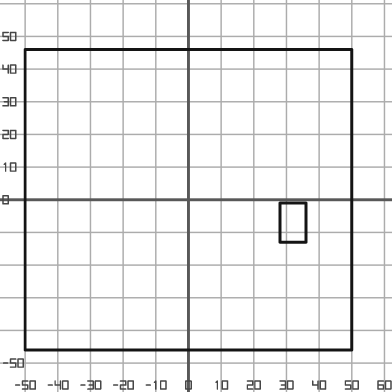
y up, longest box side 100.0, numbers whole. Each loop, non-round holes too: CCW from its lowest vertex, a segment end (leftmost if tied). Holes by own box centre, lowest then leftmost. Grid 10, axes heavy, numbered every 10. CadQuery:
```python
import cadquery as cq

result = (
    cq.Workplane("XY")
    .moveTo(-50.0, -46.0)
    .lineTo(50.0, -46.0)
    .lineTo(50.0, 46.0)
    .lineTo(-50.0, 46.0)
    .close()
    .moveTo(28.0, -13.0)
    .lineTo(36.0, -13.0)
    .lineTo(36.0, -1.0)
    .lineTo(28.0, -1.0)
    .close()
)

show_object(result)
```